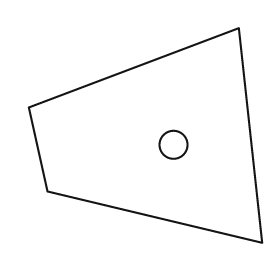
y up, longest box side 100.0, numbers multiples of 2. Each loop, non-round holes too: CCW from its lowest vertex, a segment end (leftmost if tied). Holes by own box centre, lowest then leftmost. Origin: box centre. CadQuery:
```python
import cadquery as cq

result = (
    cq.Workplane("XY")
    .moveTo(50.0, -46.0)
    .lineTo(40.0, 46.0)
    .lineTo(-50.0, 12.0)
    .lineTo(-42.0, -24.0)
    .close()
    .moveTo(12.0, -4.0)
    .circle(6.0)
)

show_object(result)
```